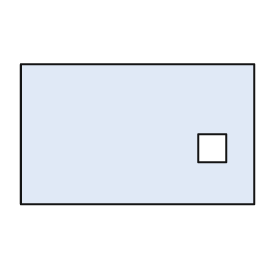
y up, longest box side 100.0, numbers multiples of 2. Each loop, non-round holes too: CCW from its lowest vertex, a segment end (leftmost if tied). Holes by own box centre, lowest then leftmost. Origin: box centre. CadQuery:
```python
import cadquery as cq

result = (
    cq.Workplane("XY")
    .moveTo(-50.0, -30.0)
    .lineTo(50.0, -30.0)
    .lineTo(50.0, 30.0)
    .lineTo(-50.0, 30.0)
    .close()
    .moveTo(26.0, -12.0)
    .lineTo(38.0, -12.0)
    .lineTo(38.0, 0.0)
    .lineTo(26.0, 0.0)
    .close()
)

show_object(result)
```